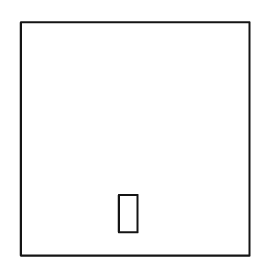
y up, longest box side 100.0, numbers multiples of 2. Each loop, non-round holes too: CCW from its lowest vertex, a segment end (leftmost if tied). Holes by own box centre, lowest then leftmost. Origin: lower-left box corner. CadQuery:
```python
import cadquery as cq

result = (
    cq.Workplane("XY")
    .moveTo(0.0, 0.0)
    .lineTo(98.0, 0.0)
    .lineTo(98.0, 100.0)
    .lineTo(0.0, 100.0)
    .close()
    .moveTo(42.0, 10.0)
    .lineTo(50.0, 10.0)
    .lineTo(50.0, 26.0)
    .lineTo(42.0, 26.0)
    .close()
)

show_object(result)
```